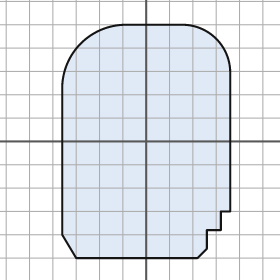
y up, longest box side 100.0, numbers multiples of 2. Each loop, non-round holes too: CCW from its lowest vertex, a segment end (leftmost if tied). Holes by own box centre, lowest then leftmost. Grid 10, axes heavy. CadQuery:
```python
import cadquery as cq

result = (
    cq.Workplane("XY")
    .moveTo(-30.0, -50.0)
    .lineTo(22.0, -50.0)
    .lineTo(26.0, -46.0)
    .lineTo(26.0, -38.0)
    .lineTo(32.0, -38.0)
    .lineTo(32.0, -30.0)
    .lineTo(36.0, -30.0)
    .lineTo(36.0, 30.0)
    .threePointArc((30.0, 44.0), (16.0, 50.0))
    .lineTo(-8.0, 50.0)
    .threePointArc((-28.0, 42.0), (-36.0, 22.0))
    .lineTo(-36.0, -40.0)
    .close()
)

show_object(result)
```